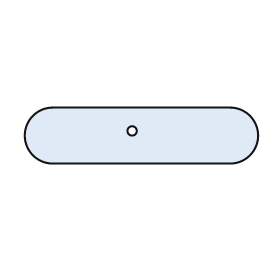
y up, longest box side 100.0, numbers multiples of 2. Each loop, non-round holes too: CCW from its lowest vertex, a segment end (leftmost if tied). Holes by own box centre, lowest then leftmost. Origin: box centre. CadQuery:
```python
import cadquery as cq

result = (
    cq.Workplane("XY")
    .moveTo(-38.0, -12.0)
    .lineTo(38.0, -12.0)
    .threePointArc((50.0, 0.0), (38.0, 12.0))
    .lineTo(-38.0, 12.0)
    .threePointArc((-50.0, 0.0), (-38.0, -12.0))
    .close()
    .moveTo(-4.0, 2.0)
    .circle(2.0)
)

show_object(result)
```